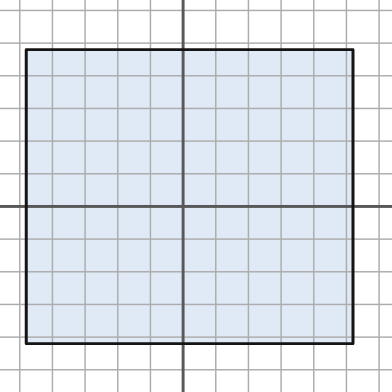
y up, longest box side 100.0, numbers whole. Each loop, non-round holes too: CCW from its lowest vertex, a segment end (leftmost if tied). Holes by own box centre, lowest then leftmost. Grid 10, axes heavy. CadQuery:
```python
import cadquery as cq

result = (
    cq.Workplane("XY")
    .moveTo(-48.0, -42.0)
    .lineTo(52.0, -42.0)
    .lineTo(52.0, 48.0)
    .lineTo(-48.0, 48.0)
    .close()
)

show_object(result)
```